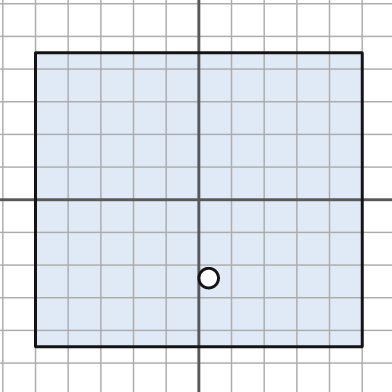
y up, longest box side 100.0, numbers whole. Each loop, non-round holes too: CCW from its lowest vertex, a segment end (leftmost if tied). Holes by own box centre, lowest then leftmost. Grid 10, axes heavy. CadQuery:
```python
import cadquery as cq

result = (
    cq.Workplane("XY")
    .moveTo(-50.0, -45.0)
    .lineTo(50.0, -45.0)
    .lineTo(50.0, 45.0)
    .lineTo(-50.0, 45.0)
    .close()
    .moveTo(3.0, -24.0)
    .circle(3.0)
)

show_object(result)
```